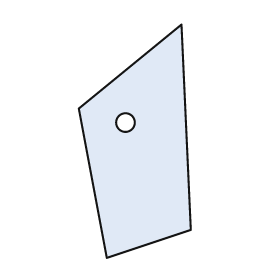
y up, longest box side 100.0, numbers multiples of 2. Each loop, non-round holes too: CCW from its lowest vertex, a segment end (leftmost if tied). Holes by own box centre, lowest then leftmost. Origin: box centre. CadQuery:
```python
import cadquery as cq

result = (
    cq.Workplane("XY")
    .moveTo(-12.0, -50.0)
    .lineTo(24.0, -38.0)
    .lineTo(20.0, 50.0)
    .lineTo(-24.0, 14.0)
    .close()
    .moveTo(-4.0, 8.0)
    .circle(4.0)
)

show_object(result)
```